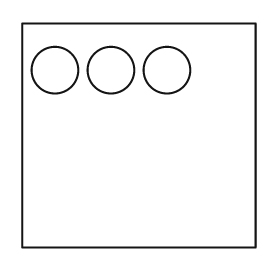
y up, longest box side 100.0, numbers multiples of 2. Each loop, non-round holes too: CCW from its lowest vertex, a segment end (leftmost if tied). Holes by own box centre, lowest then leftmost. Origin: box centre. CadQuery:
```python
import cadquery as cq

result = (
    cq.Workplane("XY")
    .moveTo(-50.0, -48.0)
    .lineTo(50.0, -48.0)
    .lineTo(50.0, 48.0)
    .lineTo(-50.0, 48.0)
    .close()
    .moveTo(-36.0, 28.0)
    .circle(10.0)
    .moveTo(-12.0, 28.0)
    .circle(10.0)
    .moveTo(12.0, 28.0)
    .circle(10.0)
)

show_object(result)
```